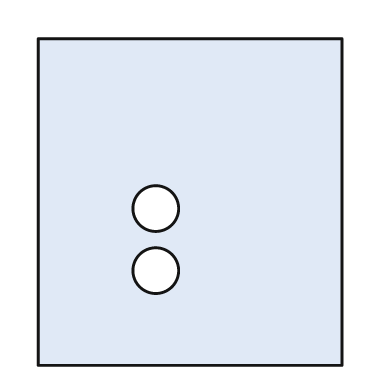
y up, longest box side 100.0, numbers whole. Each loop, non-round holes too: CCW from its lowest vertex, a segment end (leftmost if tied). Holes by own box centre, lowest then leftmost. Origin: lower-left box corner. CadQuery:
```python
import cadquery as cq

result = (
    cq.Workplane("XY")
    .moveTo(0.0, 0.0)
    .lineTo(93.0, 0.0)
    .lineTo(93.0, 100.0)
    .lineTo(0.0, 100.0)
    .close()
    .moveTo(36.0, 29.0)
    .circle(7.0)
    .moveTo(36.0, 48.0)
    .circle(7.0)
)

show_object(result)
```